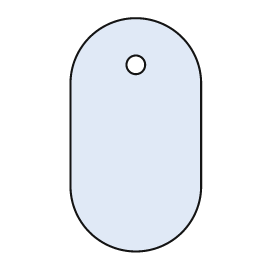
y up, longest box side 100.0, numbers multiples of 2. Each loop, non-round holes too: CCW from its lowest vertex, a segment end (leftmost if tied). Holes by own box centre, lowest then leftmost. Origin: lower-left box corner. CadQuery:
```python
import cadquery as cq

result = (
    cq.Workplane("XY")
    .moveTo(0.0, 28.0)
    .threePointArc((28.0, 0.0), (56.0, 28.0))
    .lineTo(56.0, 72.0)
    .threePointArc((28.0, 100.0), (0.0, 72.0))
    .close()
    .moveTo(28.0, 80.0)
    .circle(4.0)
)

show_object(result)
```